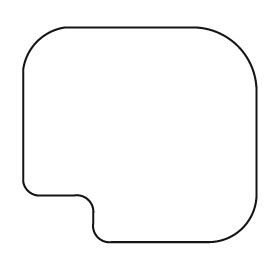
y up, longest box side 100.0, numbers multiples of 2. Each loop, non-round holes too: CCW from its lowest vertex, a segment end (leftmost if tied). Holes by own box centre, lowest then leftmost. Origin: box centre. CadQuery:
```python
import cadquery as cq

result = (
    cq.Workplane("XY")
    .moveTo(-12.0, -46.0)
    .lineTo(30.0, -46.0)
    .threePointArc((44.0, -40.0), (50.0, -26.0))
    .lineTo(50.0, 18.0)
    .threePointArc((42.0, 38.0), (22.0, 46.0))
    .lineTo(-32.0, 46.0)
    .threePointArc((-44.0, 40.0), (-50.0, 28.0))
    .lineTo(-50.0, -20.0)
    .threePointArc((-48.0, -24.0), (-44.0, -26.0))
    .lineTo(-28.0, -26.0)
    .threePointArc((-22.0, -28.0), (-20.0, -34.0))
    .lineTo(-20.0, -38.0)
    .threePointArc((-18.0, -44.0), (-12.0, -46.0))
    .close()
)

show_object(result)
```